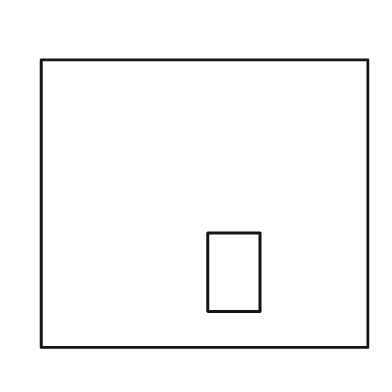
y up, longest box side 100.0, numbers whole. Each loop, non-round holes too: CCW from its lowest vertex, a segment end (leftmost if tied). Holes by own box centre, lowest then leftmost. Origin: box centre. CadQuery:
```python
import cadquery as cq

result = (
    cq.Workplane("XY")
    .moveTo(-50.0, -44.0)
    .lineTo(50.0, -44.0)
    .lineTo(50.0, 44.0)
    .lineTo(-50.0, 44.0)
    .close()
    .moveTo(1.0, -33.0)
    .lineTo(17.0, -33.0)
    .lineTo(17.0, -9.0)
    .lineTo(1.0, -9.0)
    .close()
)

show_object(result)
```